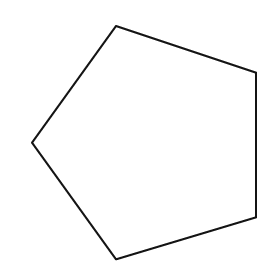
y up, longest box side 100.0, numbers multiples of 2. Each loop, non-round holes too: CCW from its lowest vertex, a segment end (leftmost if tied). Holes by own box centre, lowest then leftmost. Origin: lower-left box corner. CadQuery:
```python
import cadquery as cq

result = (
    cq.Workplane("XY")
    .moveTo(36.0, 0.0)
    .lineTo(96.0, 18.0)
    .lineTo(96.0, 80.0)
    .lineTo(36.0, 100.0)
    .lineTo(0.0, 50.0)
    .close()
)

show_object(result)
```